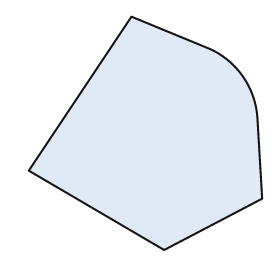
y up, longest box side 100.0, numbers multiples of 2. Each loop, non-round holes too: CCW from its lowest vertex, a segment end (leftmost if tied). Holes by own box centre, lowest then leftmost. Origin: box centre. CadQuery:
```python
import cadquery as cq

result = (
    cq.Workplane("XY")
    .moveTo(8.0, -50.0)
    .lineTo(50.0, -28.0)
    .lineTo(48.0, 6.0)
    .threePointArc((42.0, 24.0), (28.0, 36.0))
    .lineTo(-6.0, 50.0)
    .lineTo(-50.0, -16.0)
    .close()
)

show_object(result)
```